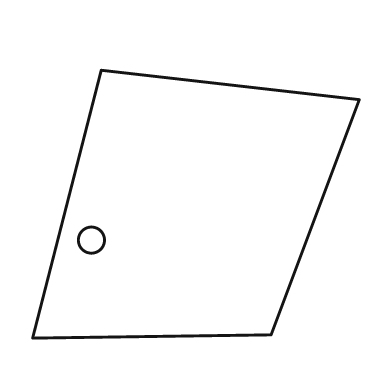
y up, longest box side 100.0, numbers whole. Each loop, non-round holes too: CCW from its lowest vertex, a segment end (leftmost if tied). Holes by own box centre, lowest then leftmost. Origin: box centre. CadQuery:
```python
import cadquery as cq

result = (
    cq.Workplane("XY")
    .moveTo(-50.0, -41.0)
    .lineTo(23.0, -40.0)
    .lineTo(50.0, 32.0)
    .lineTo(-29.0, 41.0)
    .close()
    .moveTo(-32.0, -11.0)
    .circle(4.0)
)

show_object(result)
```